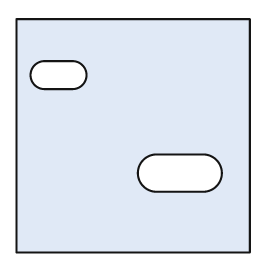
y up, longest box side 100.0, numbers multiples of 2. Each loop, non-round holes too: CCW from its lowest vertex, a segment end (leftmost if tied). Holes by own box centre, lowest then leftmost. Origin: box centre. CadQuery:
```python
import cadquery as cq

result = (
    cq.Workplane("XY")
    .moveTo(-50.0, -50.0)
    .lineTo(50.0, -50.0)
    .lineTo(50.0, 50.0)
    .lineTo(-50.0, 50.0)
    .close()
    .moveTo(10.0, -24.0)
    .lineTo(30.0, -24.0)
    .threePointArc((38.0, -16.0), (30.0, -8.0))
    .lineTo(10.0, -8.0)
    .threePointArc((2.0, -16.0), (10.0, -24.0))
    .close()
    .moveTo(-38.0, 20.0)
    .lineTo(-26.0, 20.0)
    .threePointArc((-20.0, 26.0), (-26.0, 32.0))
    .lineTo(-38.0, 32.0)
    .threePointArc((-44.0, 26.0), (-38.0, 20.0))
    .close()
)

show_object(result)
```